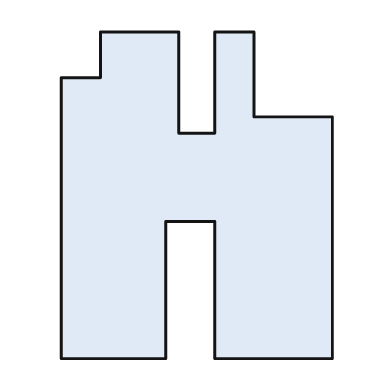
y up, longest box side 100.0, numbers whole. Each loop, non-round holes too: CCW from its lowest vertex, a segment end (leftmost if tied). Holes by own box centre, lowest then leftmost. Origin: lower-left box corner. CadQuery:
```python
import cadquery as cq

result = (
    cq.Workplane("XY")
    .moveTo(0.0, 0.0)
    .lineTo(32.0, 0.0)
    .lineTo(32.0, 42.0)
    .lineTo(47.0, 42.0)
    .lineTo(47.0, 0.0)
    .lineTo(83.0, 0.0)
    .lineTo(83.0, 74.0)
    .lineTo(59.0, 74.0)
    .lineTo(59.0, 100.0)
    .lineTo(47.0, 100.0)
    .lineTo(47.0, 69.0)
    .lineTo(36.0, 69.0)
    .lineTo(36.0, 100.0)
    .lineTo(12.0, 100.0)
    .lineTo(12.0, 86.0)
    .lineTo(0.0, 86.0)
    .close()
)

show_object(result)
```